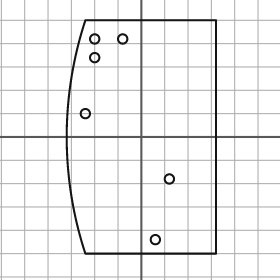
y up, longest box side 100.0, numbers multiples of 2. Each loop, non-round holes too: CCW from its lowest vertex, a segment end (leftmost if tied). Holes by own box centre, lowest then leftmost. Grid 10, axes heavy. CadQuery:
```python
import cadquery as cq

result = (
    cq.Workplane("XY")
    .moveTo(-24.0, -50.0)
    .lineTo(32.0, -50.0)
    .lineTo(32.0, 50.0)
    .lineTo(-24.0, 50.0)
    .threePointArc((-32.0, 0.0), (-24.0, -50.0))
    .close()
    .moveTo(6.0, -44.0)
    .circle(2.0)
    .moveTo(12.0, -18.0)
    .circle(2.0)
    .moveTo(-24.0, 10.0)
    .circle(2.0)
    .moveTo(-20.0, 34.0)
    .circle(2.0)
    .moveTo(-20.0, 42.0)
    .circle(2.0)
    .moveTo(-8.0, 42.0)
    .circle(2.0)
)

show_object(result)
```